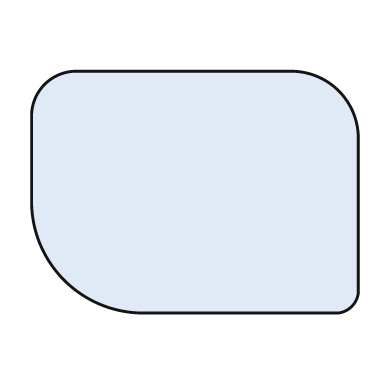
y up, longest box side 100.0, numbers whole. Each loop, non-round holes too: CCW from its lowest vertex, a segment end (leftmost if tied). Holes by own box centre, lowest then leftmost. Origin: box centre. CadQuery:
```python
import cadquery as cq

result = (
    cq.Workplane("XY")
    .moveTo(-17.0, -37.0)
    .lineTo(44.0, -37.0)
    .threePointArc((48.0, -35.0), (50.0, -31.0))
    .lineTo(50.0, 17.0)
    .threePointArc((44.0, 31.0), (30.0, 37.0))
    .lineTo(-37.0, 37.0)
    .threePointArc((-46.0, 33.0), (-50.0, 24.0))
    .lineTo(-50.0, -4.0)
    .threePointArc((-40.0, -27.0), (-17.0, -37.0))
    .close()
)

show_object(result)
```